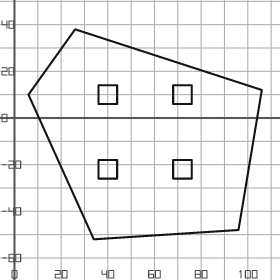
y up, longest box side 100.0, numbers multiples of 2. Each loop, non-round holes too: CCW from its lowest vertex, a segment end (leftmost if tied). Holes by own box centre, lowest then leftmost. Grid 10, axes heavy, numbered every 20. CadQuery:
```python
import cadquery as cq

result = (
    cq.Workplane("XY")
    .moveTo(34.0, -52.0)
    .lineTo(96.0, -48.0)
    .lineTo(106.0, 12.0)
    .lineTo(26.0, 38.0)
    .lineTo(6.0, 10.0)
    .close()
    .moveTo(36.0, -26.0)
    .lineTo(44.0, -26.0)
    .lineTo(44.0, -18.0)
    .lineTo(36.0, -18.0)
    .close()
    .moveTo(68.0, -26.0)
    .lineTo(76.0, -26.0)
    .lineTo(76.0, -18.0)
    .lineTo(68.0, -18.0)
    .close()
    .moveTo(36.0, 6.0)
    .lineTo(44.0, 6.0)
    .lineTo(44.0, 14.0)
    .lineTo(36.0, 14.0)
    .close()
    .moveTo(68.0, 6.0)
    .lineTo(76.0, 6.0)
    .lineTo(76.0, 14.0)
    .lineTo(68.0, 14.0)
    .close()
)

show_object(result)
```